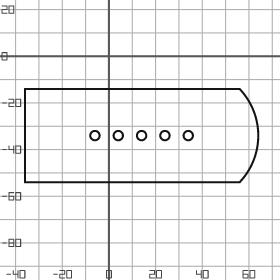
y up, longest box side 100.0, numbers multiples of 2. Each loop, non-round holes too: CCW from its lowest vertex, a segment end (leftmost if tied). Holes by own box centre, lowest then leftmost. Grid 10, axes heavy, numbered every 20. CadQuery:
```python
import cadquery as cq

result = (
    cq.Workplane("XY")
    .moveTo(-36.0, -54.0)
    .lineTo(56.0, -54.0)
    .threePointArc((64.0, -34.0), (56.0, -14.0))
    .lineTo(-36.0, -14.0)
    .close()
    .moveTo(-6.0, -34.0)
    .circle(2.0)
    .moveTo(4.0, -34.0)
    .circle(2.0)
    .moveTo(14.0, -34.0)
    .circle(2.0)
    .moveTo(24.0, -34.0)
    .circle(2.0)
    .moveTo(34.0, -34.0)
    .circle(2.0)
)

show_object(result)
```